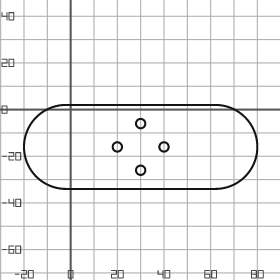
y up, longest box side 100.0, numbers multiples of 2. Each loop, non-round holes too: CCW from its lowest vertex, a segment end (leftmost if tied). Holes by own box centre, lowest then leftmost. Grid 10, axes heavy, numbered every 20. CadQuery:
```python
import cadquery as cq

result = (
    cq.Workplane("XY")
    .moveTo(-2.0, -34.0)
    .lineTo(62.0, -34.0)
    .threePointArc((80.0, -16.0), (62.0, 2.0))
    .lineTo(-2.0, 2.0)
    .threePointArc((-20.0, -16.0), (-2.0, -34.0))
    .close()
    .moveTo(30.0, -26.0)
    .circle(2.0)
    .moveTo(20.0, -16.0)
    .circle(2.0)
    .moveTo(40.0, -16.0)
    .circle(2.0)
    .moveTo(30.0, -6.0)
    .circle(2.0)
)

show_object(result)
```